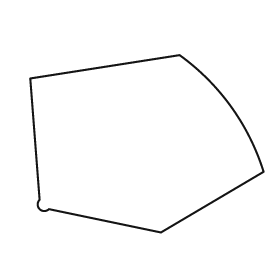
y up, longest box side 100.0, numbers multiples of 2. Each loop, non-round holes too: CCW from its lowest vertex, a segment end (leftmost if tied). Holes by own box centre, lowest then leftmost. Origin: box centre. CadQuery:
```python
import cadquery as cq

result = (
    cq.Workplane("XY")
    .moveTo(6.0, -38.0)
    .lineTo(50.0, -12.0)
    .threePointArc((36.0, 16.0), (14.0, 38.0))
    .lineTo(-50.0, 28.0)
    .lineTo(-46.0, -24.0)
    .threePointArc((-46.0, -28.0), (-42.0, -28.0))
    .close()
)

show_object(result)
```